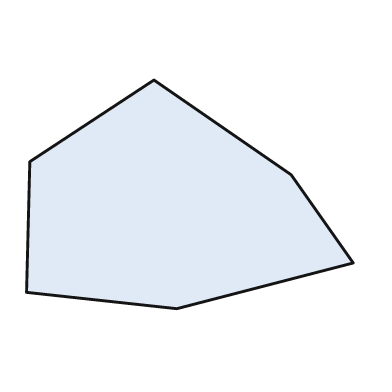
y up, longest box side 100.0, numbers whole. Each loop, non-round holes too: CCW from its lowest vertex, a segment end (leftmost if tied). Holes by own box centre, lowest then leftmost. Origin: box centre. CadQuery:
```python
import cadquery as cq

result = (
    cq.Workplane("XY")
    .moveTo(-4.0, -35.0)
    .lineTo(50.0, -21.0)
    .lineTo(31.0, 6.0)
    .lineTo(-11.0, 35.0)
    .lineTo(-49.0, 10.0)
    .lineTo(-50.0, -30.0)
    .close()
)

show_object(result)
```